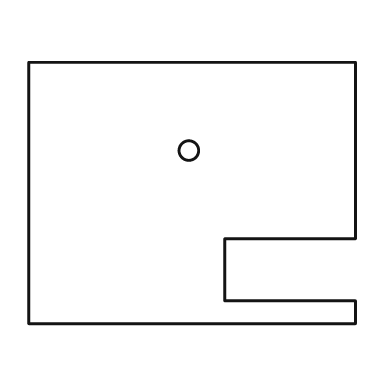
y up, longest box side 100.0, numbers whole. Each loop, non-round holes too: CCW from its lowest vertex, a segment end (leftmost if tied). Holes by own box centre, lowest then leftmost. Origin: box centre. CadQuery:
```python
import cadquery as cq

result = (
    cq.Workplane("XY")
    .moveTo(-50.0, -40.0)
    .lineTo(50.0, -40.0)
    .lineTo(50.0, -33.0)
    .lineTo(10.0, -33.0)
    .lineTo(10.0, -14.0)
    .lineTo(50.0, -14.0)
    .lineTo(50.0, 40.0)
    .lineTo(-50.0, 40.0)
    .close()
    .moveTo(-1.0, 13.0)
    .circle(3.0)
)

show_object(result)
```